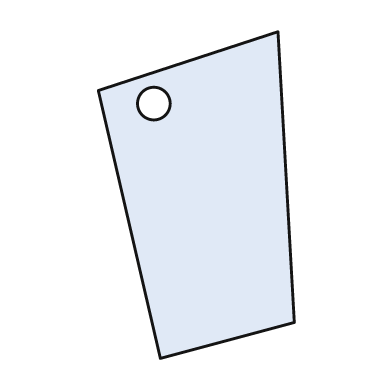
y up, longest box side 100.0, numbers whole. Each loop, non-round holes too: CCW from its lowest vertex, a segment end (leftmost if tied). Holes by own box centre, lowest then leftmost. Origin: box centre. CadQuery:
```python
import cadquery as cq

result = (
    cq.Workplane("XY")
    .moveTo(-11.0, -50.0)
    .lineTo(30.0, -39.0)
    .lineTo(25.0, 50.0)
    .lineTo(-30.0, 32.0)
    .close()
    .moveTo(-13.0, 28.0)
    .circle(5.0)
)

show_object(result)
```